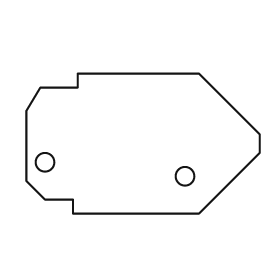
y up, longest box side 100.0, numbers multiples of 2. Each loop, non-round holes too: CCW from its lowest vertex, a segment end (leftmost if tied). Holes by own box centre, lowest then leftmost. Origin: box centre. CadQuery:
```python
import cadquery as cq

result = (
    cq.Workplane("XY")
    .moveTo(-30.0, -30.0)
    .lineTo(24.0, -30.0)
    .lineTo(50.0, -4.0)
    .lineTo(50.0, 4.0)
    .lineTo(24.0, 30.0)
    .lineTo(-28.0, 30.0)
    .lineTo(-28.0, 24.0)
    .lineTo(-44.0, 24.0)
    .lineTo(-50.0, 14.0)
    .lineTo(-50.0, -16.0)
    .lineTo(-42.0, -24.0)
    .lineTo(-30.0, -24.0)
    .close()
    .moveTo(18.0, -14.0)
    .circle(4.0)
    .moveTo(-42.0, -8.0)
    .circle(4.0)
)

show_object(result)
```